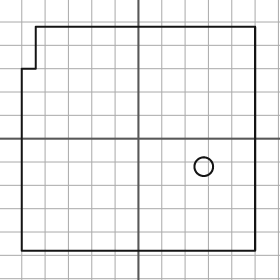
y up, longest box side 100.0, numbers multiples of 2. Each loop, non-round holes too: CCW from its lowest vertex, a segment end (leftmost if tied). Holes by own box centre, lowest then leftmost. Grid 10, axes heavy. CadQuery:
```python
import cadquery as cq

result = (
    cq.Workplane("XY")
    .moveTo(-50.0, -48.0)
    .lineTo(50.0, -48.0)
    .lineTo(50.0, 48.0)
    .lineTo(-44.0, 48.0)
    .lineTo(-44.0, 30.0)
    .lineTo(-50.0, 30.0)
    .close()
    .moveTo(28.0, -12.0)
    .circle(4.0)
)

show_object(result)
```